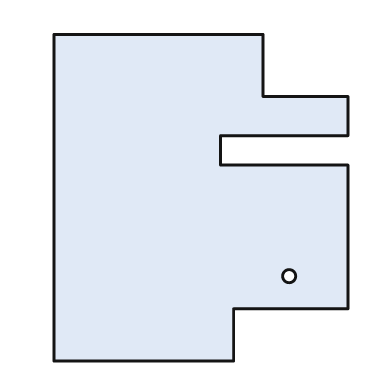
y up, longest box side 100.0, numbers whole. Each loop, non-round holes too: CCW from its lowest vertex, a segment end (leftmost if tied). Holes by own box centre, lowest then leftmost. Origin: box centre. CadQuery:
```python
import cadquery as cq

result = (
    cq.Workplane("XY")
    .moveTo(-45.0, -50.0)
    .lineTo(10.0, -50.0)
    .lineTo(10.0, -34.0)
    .lineTo(45.0, -34.0)
    .lineTo(45.0, 10.0)
    .lineTo(6.0, 10.0)
    .lineTo(6.0, 19.0)
    .lineTo(45.0, 19.0)
    .lineTo(45.0, 31.0)
    .lineTo(19.0, 31.0)
    .lineTo(19.0, 50.0)
    .lineTo(-45.0, 50.0)
    .close()
    .moveTo(27.0, -24.0)
    .circle(2.0)
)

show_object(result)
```